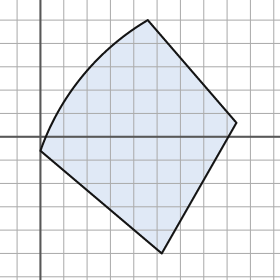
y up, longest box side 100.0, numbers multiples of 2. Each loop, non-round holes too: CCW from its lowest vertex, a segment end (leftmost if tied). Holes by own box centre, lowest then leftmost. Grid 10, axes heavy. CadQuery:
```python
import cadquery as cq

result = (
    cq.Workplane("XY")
    .moveTo(52.0, -50.0)
    .lineTo(84.0, 6.0)
    .lineTo(46.0, 50.0)
    .threePointArc((18.0, 26.0), (0.0, -6.0))
    .close()
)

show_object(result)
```